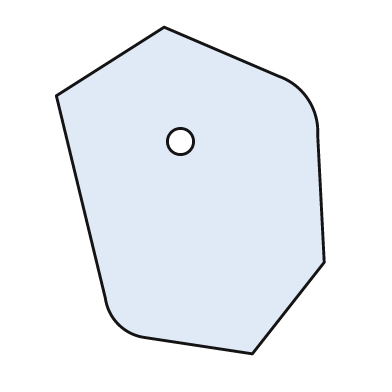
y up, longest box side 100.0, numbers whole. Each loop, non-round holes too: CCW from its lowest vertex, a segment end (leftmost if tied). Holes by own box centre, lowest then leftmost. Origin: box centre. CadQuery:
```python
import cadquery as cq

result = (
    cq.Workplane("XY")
    .moveTo(19.0, -50.0)
    .lineTo(41.0, -22.0)
    .lineTo(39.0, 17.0)
    .threePointArc((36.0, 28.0), (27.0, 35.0))
    .lineTo(-8.0, 50.0)
    .lineTo(-41.0, 29.0)
    .lineTo(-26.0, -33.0)
    .threePointArc((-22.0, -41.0), (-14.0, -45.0))
    .close()
    .moveTo(-3.0, 15.0)
    .circle(4.0)
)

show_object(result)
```